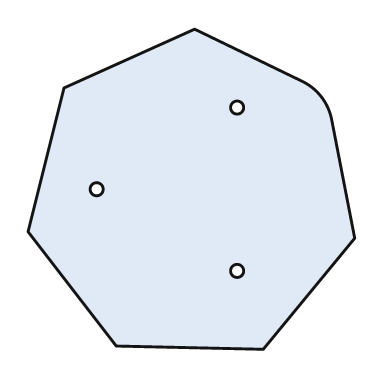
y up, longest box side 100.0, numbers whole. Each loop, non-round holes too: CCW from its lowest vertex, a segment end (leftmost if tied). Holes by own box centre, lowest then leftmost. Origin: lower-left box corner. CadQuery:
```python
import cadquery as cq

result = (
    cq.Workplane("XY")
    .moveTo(72.0, 0.0)
    .lineTo(100.0, 34.0)
    .lineTo(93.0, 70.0)
    .threePointArc((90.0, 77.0), (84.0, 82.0))
    .lineTo(51.0, 98.0)
    .lineTo(11.0, 80.0)
    .lineTo(0.0, 36.0)
    .lineTo(27.0, 1.0)
    .close()
    .moveTo(64.0, 24.0)
    .circle(2.0)
    .moveTo(21.0, 49.0)
    .circle(2.0)
    .moveTo(64.0, 74.0)
    .circle(2.0)
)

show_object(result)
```